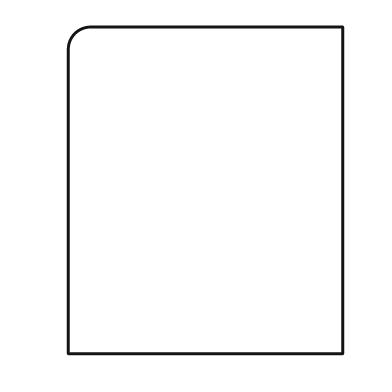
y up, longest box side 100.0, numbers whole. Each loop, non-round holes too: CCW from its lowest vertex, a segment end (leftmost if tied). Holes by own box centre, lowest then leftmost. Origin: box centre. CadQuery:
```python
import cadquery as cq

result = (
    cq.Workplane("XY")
    .moveTo(-42.0, -50.0)
    .lineTo(42.0, -50.0)
    .lineTo(42.0, 50.0)
    .lineTo(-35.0, 50.0)
    .threePointArc((-40.0, 48.0), (-42.0, 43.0))
    .close()
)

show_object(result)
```